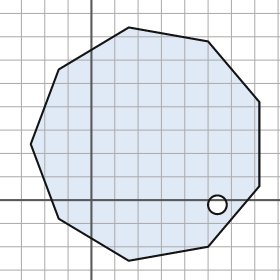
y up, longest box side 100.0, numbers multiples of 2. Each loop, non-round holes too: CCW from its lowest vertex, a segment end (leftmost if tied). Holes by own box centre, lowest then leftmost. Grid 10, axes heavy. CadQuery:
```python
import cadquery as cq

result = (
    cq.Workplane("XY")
    .moveTo(16.0, -26.0)
    .lineTo(50.0, -20.0)
    .lineTo(72.0, 6.0)
    .lineTo(72.0, 42.0)
    .lineTo(50.0, 68.0)
    .lineTo(16.0, 74.0)
    .lineTo(-14.0, 56.0)
    .lineTo(-26.0, 24.0)
    .lineTo(-14.0, -8.0)
    .close()
    .moveTo(54.0, -2.0)
    .circle(4.0)
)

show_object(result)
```